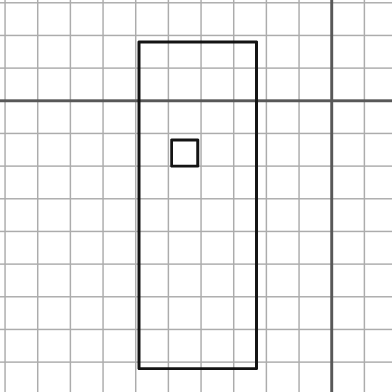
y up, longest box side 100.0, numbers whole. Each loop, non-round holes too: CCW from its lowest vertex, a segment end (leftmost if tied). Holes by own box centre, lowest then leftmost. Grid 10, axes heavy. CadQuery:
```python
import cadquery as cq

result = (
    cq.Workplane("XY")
    .moveTo(-59.0, -82.0)
    .lineTo(-23.0, -82.0)
    .lineTo(-23.0, 18.0)
    .lineTo(-59.0, 18.0)
    .close()
    .moveTo(-49.0, -20.0)
    .lineTo(-41.0, -20.0)
    .lineTo(-41.0, -12.0)
    .lineTo(-49.0, -12.0)
    .close()
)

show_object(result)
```